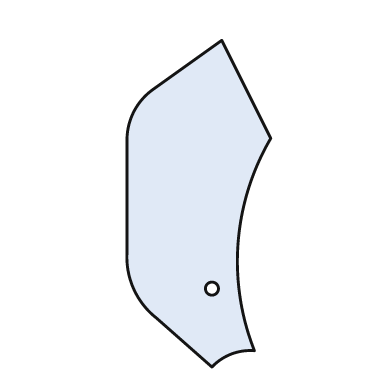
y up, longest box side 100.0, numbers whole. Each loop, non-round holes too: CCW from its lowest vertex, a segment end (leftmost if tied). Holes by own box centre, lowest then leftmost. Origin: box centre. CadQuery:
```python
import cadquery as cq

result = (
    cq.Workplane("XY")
    .moveTo(4.0, -50.0)
    .threePointArc((10.0, -46.0), (17.0, -45.0))
    .threePointArc((12.0, -12.0), (22.0, 20.0))
    .lineTo(7.0, 50.0)
    .lineTo(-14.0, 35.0)
    .threePointArc((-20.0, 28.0), (-22.0, 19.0))
    .lineTo(-22.0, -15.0)
    .threePointArc((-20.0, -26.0), (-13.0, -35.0))
    .close()
    .moveTo(4.0, -26.0)
    .circle(2.0)
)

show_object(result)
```